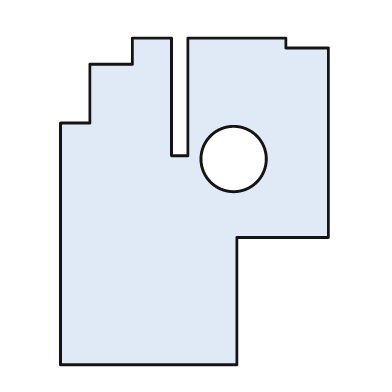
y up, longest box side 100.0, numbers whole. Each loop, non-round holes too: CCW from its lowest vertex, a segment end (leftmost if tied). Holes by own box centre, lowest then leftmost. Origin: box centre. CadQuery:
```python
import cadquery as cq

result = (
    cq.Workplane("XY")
    .moveTo(-41.0, -50.0)
    .lineTo(13.0, -50.0)
    .lineTo(13.0, -11.0)
    .lineTo(41.0, -11.0)
    .lineTo(41.0, 47.0)
    .lineTo(28.0, 47.0)
    .lineTo(28.0, 50.0)
    .lineTo(-2.0, 50.0)
    .lineTo(-2.0, 14.0)
    .lineTo(-7.0, 14.0)
    .lineTo(-7.0, 50.0)
    .lineTo(-19.0, 50.0)
    .lineTo(-19.0, 42.0)
    .lineTo(-32.0, 42.0)
    .lineTo(-32.0, 24.0)
    .lineTo(-41.0, 24.0)
    .close()
    .moveTo(12.0, 13.0)
    .circle(10.0)
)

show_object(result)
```